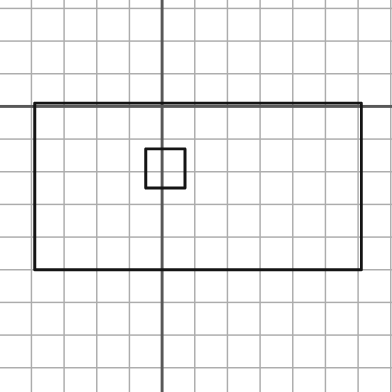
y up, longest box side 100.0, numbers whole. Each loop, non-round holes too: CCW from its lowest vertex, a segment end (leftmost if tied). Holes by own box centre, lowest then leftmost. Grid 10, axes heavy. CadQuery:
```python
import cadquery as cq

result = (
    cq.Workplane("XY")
    .moveTo(-39.0, -50.0)
    .lineTo(61.0, -50.0)
    .lineTo(61.0, 1.0)
    .lineTo(-39.0, 1.0)
    .close()
    .moveTo(-5.0, -25.0)
    .lineTo(7.0, -25.0)
    .lineTo(7.0, -13.0)
    .lineTo(-5.0, -13.0)
    .close()
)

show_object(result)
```